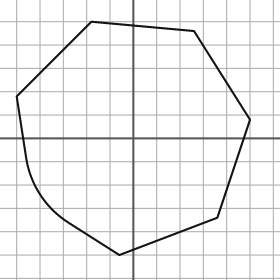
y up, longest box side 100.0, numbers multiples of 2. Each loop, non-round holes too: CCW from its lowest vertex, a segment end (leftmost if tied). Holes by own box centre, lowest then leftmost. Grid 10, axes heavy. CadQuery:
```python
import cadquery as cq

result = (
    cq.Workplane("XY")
    .moveTo(-6.0, -50.0)
    .lineTo(36.0, -34.0)
    .lineTo(50.0, 8.0)
    .lineTo(26.0, 46.0)
    .lineTo(-18.0, 50.0)
    .lineTo(-50.0, 18.0)
    .lineTo(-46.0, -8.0)
    .threePointArc((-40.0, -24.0), (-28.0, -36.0))
    .close()
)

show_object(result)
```